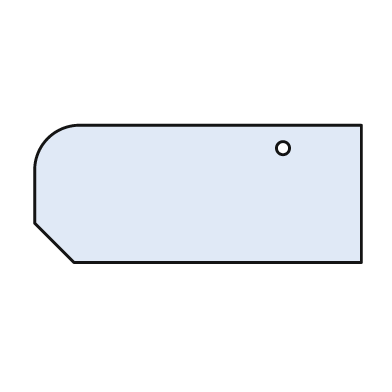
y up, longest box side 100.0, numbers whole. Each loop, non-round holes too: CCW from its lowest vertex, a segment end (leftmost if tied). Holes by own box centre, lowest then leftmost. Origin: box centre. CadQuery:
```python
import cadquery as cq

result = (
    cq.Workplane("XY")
    .moveTo(-38.0, -21.0)
    .lineTo(50.0, -21.0)
    .lineTo(50.0, 21.0)
    .lineTo(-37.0, 21.0)
    .threePointArc((-46.0, 17.0), (-50.0, 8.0))
    .lineTo(-50.0, -9.0)
    .close()
    .moveTo(26.0, 14.0)
    .circle(2.0)
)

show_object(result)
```